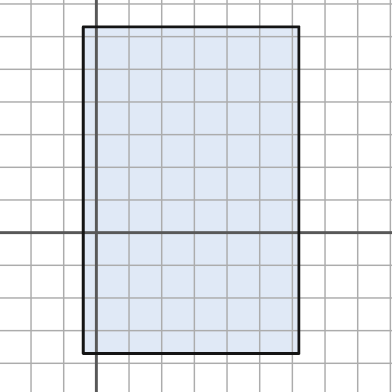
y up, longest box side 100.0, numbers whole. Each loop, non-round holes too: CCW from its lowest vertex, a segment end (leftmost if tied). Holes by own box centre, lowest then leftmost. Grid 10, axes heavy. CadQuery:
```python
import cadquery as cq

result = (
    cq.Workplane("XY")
    .moveTo(-4.0, -37.0)
    .lineTo(62.0, -37.0)
    .lineTo(62.0, 63.0)
    .lineTo(-4.0, 63.0)
    .close()
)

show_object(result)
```